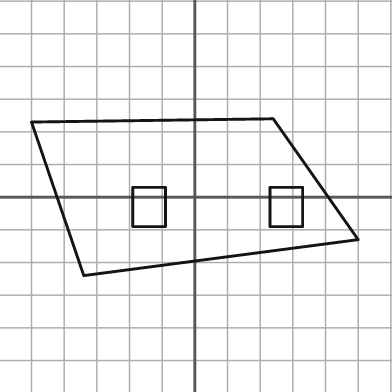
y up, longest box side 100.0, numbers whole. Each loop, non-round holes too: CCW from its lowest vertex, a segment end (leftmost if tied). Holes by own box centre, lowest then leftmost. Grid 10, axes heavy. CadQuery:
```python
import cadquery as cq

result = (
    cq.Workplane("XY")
    .moveTo(-34.0, -24.0)
    .lineTo(50.0, -13.0)
    .lineTo(24.0, 24.0)
    .lineTo(-50.0, 23.0)
    .close()
    .moveTo(-19.0, -9.0)
    .lineTo(-9.0, -9.0)
    .lineTo(-9.0, 3.0)
    .lineTo(-19.0, 3.0)
    .close()
    .moveTo(23.0, -9.0)
    .lineTo(33.0, -9.0)
    .lineTo(33.0, 3.0)
    .lineTo(23.0, 3.0)
    .close()
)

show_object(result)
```